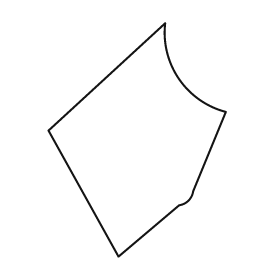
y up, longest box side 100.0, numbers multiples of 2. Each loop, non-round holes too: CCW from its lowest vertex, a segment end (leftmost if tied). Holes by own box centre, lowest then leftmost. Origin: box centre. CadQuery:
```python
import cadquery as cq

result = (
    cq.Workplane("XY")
    .moveTo(-8.0, -50.0)
    .lineTo(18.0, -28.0)
    .threePointArc((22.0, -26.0), (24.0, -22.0))
    .lineTo(38.0, 12.0)
    .threePointArc((18.0, 26.0), (12.0, 50.0))
    .lineTo(-38.0, 4.0)
    .close()
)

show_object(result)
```